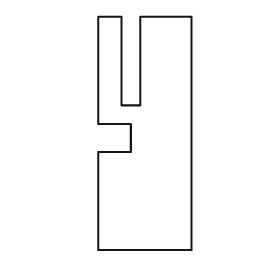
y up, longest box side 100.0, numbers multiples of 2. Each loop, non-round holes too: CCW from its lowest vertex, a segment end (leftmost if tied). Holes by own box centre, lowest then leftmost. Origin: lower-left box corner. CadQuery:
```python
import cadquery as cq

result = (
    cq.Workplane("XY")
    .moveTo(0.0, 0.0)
    .lineTo(40.0, 0.0)
    .lineTo(40.0, 100.0)
    .lineTo(18.0, 100.0)
    .lineTo(18.0, 62.0)
    .lineTo(10.0, 62.0)
    .lineTo(10.0, 100.0)
    .lineTo(0.0, 100.0)
    .lineTo(0.0, 54.0)
    .lineTo(14.0, 54.0)
    .lineTo(14.0, 42.0)
    .lineTo(0.0, 42.0)
    .close()
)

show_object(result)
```